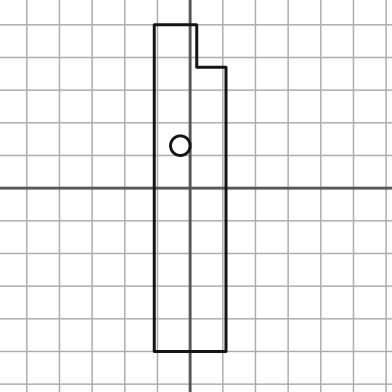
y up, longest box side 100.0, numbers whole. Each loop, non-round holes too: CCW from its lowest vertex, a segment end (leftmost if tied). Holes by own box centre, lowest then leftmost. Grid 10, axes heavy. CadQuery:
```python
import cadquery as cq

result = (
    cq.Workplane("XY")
    .moveTo(-11.0, -50.0)
    .lineTo(11.0, -50.0)
    .lineTo(11.0, 37.0)
    .lineTo(2.0, 37.0)
    .lineTo(2.0, 50.0)
    .lineTo(-11.0, 50.0)
    .close()
    .moveTo(-3.0, 13.0)
    .circle(3.0)
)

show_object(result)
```